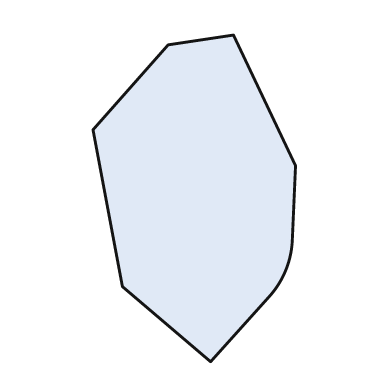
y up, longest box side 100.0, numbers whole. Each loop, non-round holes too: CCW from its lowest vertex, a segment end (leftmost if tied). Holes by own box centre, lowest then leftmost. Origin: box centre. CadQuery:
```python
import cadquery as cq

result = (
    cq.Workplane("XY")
    .moveTo(5.0, -50.0)
    .lineTo(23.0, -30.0)
    .threePointArc((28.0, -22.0), (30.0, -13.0))
    .lineTo(31.0, 10.0)
    .lineTo(12.0, 50.0)
    .lineTo(-8.0, 47.0)
    .lineTo(-31.0, 21.0)
    .lineTo(-22.0, -27.0)
    .close()
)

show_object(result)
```